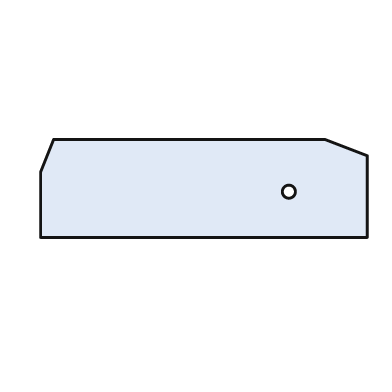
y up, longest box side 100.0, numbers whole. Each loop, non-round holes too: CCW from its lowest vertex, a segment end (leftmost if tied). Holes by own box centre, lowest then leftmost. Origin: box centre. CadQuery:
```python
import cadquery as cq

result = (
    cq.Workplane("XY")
    .moveTo(-50.0, -15.0)
    .lineTo(50.0, -15.0)
    .lineTo(50.0, 10.0)
    .lineTo(37.0, 15.0)
    .lineTo(-46.0, 15.0)
    .lineTo(-50.0, 5.0)
    .close()
    .moveTo(26.0, -1.0)
    .circle(2.0)
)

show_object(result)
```